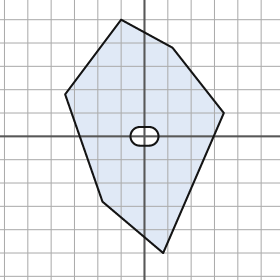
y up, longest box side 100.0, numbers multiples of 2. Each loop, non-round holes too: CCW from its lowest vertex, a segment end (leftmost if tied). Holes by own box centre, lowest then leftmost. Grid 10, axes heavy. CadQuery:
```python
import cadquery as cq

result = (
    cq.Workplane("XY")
    .moveTo(8.0, -50.0)
    .lineTo(34.0, 10.0)
    .lineTo(12.0, 38.0)
    .lineTo(-10.0, 50.0)
    .lineTo(-34.0, 18.0)
    .lineTo(-18.0, -28.0)
    .close()
    .moveTo(-2.0, -4.0)
    .lineTo(2.0, -4.0)
    .threePointArc((6.0, 0.0), (2.0, 4.0))
    .lineTo(-2.0, 4.0)
    .threePointArc((-6.0, 0.0), (-2.0, -4.0))
    .close()
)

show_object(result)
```